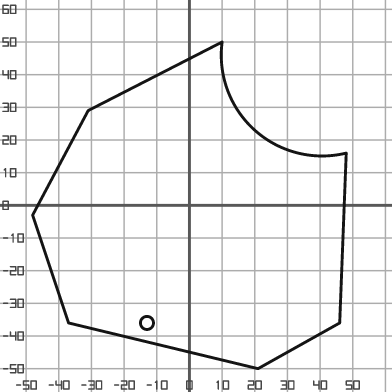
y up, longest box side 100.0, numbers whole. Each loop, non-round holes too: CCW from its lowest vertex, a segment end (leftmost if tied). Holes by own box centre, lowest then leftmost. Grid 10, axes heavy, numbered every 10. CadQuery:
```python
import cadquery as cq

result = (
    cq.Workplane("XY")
    .moveTo(21.0, -50.0)
    .lineTo(46.0, -36.0)
    .lineTo(48.0, 16.0)
    .threePointArc((20.0, 23.0), (10.0, 50.0))
    .lineTo(-31.0, 29.0)
    .lineTo(-48.0, -3.0)
    .lineTo(-37.0, -36.0)
    .close()
    .moveTo(-13.0, -36.0)
    .circle(2.0)
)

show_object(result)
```